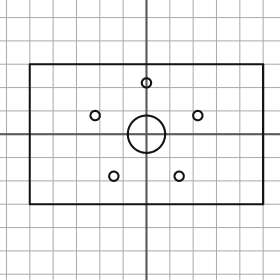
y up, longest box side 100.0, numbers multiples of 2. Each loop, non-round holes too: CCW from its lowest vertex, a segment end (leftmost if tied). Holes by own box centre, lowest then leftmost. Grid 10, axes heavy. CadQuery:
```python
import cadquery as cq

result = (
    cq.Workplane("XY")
    .moveTo(-50.0, -30.0)
    .lineTo(50.0, -30.0)
    .lineTo(50.0, 30.0)
    .lineTo(-50.0, 30.0)
    .close()
    .moveTo(-14.0, -18.0)
    .circle(2.0)
    .moveTo(14.0, -18.0)
    .circle(2.0)
    .moveTo(0.0, 0.0)
    .circle(8.0)
    .moveTo(-22.0, 8.0)
    .circle(2.0)
    .moveTo(22.0, 8.0)
    .circle(2.0)
    .moveTo(0.0, 22.0)
    .circle(2.0)
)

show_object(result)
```